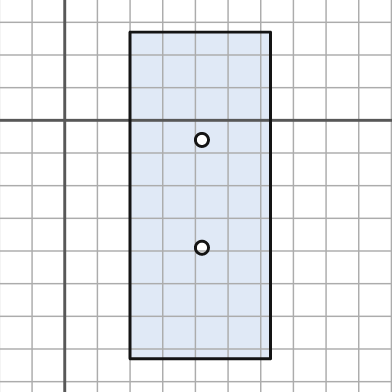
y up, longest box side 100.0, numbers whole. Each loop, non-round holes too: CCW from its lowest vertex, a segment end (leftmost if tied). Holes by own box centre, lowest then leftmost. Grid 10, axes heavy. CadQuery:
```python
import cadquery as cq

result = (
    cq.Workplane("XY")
    .moveTo(20.0, -73.0)
    .lineTo(63.0, -73.0)
    .lineTo(63.0, 27.0)
    .lineTo(20.0, 27.0)
    .close()
    .moveTo(42.0, -39.0)
    .circle(2.0)
    .moveTo(42.0, -6.0)
    .circle(2.0)
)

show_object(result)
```